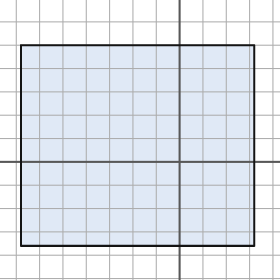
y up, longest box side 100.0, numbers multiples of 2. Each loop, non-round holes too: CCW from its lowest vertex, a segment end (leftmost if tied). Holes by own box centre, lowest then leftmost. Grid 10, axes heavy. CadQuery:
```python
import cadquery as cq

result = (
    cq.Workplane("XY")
    .moveTo(-68.0, -36.0)
    .lineTo(32.0, -36.0)
    .lineTo(32.0, 50.0)
    .lineTo(-68.0, 50.0)
    .close()
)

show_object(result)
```